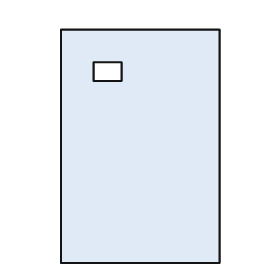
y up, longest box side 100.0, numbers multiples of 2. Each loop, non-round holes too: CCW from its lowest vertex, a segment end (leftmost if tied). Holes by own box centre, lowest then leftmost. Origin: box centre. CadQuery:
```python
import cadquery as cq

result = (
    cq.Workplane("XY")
    .moveTo(-34.0, -50.0)
    .lineTo(34.0, -50.0)
    .lineTo(34.0, 50.0)
    .lineTo(-34.0, 50.0)
    .close()
    .moveTo(-20.0, 28.0)
    .lineTo(-8.0, 28.0)
    .lineTo(-8.0, 36.0)
    .lineTo(-20.0, 36.0)
    .close()
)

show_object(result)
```